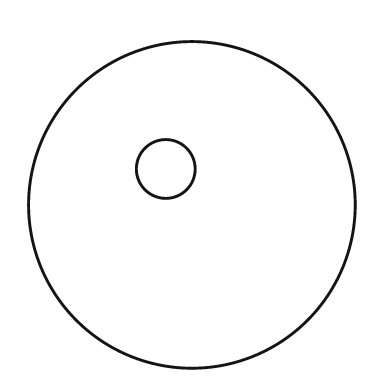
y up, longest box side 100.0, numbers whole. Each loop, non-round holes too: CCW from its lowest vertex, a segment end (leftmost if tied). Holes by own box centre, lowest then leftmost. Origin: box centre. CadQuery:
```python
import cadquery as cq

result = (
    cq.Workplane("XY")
    .moveTo(0.0, 0.0)
    .circle(50.0)
    .moveTo(-8.0, 11.0)
    .circle(9.0)
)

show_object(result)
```